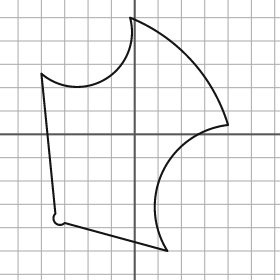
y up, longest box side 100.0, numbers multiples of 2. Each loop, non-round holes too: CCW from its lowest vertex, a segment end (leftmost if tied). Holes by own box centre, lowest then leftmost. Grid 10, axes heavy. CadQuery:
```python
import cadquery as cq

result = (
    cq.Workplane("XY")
    .moveTo(14.0, -50.0)
    .threePointArc((12.0, -16.0), (40.0, 4.0))
    .threePointArc((24.0, 32.0), (-2.0, 50.0))
    .threePointArc((-12.0, 24.0), (-40.0, 26.0))
    .lineTo(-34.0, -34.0)
    .threePointArc((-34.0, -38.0), (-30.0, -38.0))
    .close()
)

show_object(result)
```